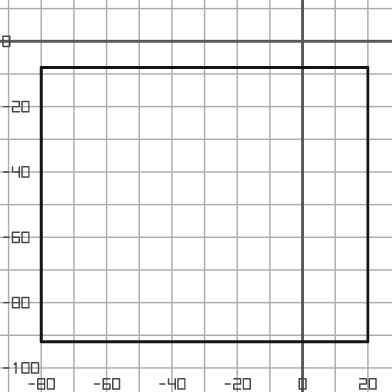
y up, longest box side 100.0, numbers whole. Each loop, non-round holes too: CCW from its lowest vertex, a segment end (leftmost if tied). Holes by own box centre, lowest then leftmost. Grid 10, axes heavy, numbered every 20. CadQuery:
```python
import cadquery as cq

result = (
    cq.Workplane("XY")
    .moveTo(-80.0, -92.0)
    .lineTo(20.0, -92.0)
    .lineTo(20.0, -8.0)
    .lineTo(-80.0, -8.0)
    .close()
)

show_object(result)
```